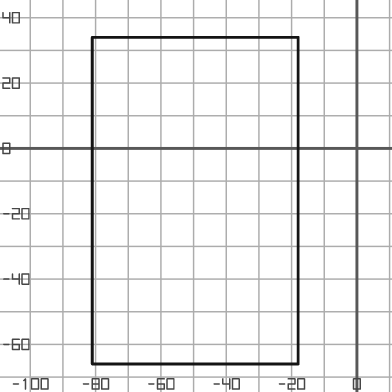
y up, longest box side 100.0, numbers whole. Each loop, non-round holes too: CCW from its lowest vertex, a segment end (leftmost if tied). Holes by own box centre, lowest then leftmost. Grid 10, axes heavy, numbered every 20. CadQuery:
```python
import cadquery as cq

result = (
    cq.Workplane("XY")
    .moveTo(-81.0, -66.0)
    .lineTo(-18.0, -66.0)
    .lineTo(-18.0, 34.0)
    .lineTo(-81.0, 34.0)
    .close()
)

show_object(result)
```